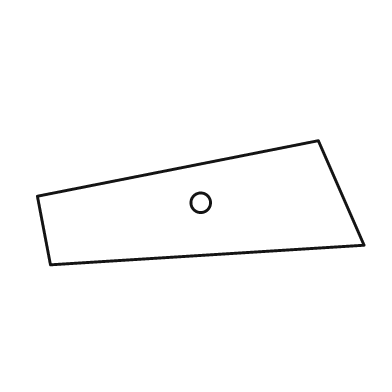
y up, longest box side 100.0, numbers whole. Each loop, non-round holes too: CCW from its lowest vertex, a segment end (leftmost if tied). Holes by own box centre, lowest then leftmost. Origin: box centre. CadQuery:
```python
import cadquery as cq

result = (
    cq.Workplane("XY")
    .moveTo(-46.0, -19.0)
    .lineTo(50.0, -13.0)
    .lineTo(36.0, 19.0)
    .lineTo(-50.0, 2.0)
    .close()
    .moveTo(0.0, 0.0)
    .circle(3.0)
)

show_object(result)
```